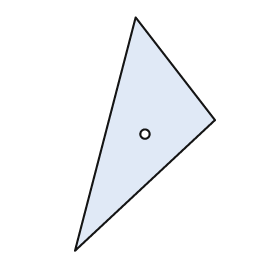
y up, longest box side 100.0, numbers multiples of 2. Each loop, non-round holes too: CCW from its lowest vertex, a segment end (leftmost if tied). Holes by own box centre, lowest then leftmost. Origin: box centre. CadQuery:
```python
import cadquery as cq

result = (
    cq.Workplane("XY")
    .moveTo(-30.0, -50.0)
    .lineTo(30.0, 6.0)
    .lineTo(-4.0, 50.0)
    .close()
    .moveTo(0.0, 0.0)
    .circle(2.0)
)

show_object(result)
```